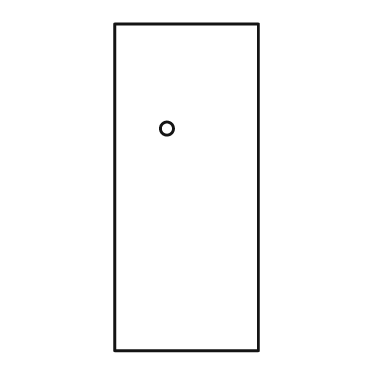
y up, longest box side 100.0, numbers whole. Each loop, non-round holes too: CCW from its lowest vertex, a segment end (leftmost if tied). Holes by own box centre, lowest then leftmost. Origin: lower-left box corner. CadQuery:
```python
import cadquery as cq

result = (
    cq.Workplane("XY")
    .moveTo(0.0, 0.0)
    .lineTo(44.0, 0.0)
    .lineTo(44.0, 100.0)
    .lineTo(0.0, 100.0)
    .close()
    .moveTo(16.0, 68.0)
    .circle(2.0)
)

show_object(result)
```